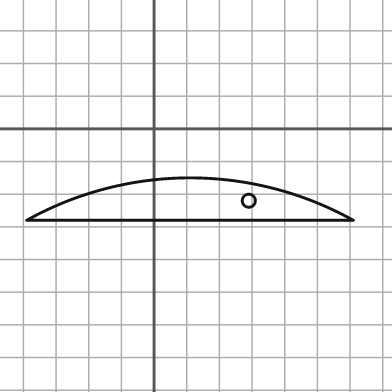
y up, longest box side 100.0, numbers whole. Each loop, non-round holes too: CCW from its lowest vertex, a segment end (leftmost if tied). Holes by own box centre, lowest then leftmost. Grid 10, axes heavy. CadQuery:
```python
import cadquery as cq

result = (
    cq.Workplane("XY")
    .moveTo(-39.0, -28.0)
    .lineTo(61.0, -28.0)
    .threePointArc((11.0, -15.0), (-39.0, -28.0))
    .close()
    .moveTo(29.0, -22.0)
    .circle(2.0)
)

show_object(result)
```